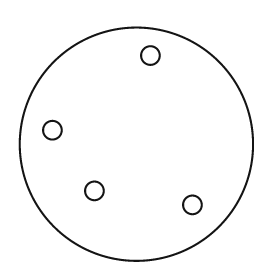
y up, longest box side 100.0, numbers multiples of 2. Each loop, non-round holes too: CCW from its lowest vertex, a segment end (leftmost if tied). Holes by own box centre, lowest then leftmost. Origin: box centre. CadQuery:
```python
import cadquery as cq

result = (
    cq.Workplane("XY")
    .moveTo(0.0, 0.0)
    .circle(50.0)
    .moveTo(24.0, -26.0)
    .circle(4.0)
    .moveTo(-18.0, -20.0)
    .circle(4.0)
    .moveTo(-36.0, 6.0)
    .circle(4.0)
    .moveTo(6.0, 38.0)
    .circle(4.0)
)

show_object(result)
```